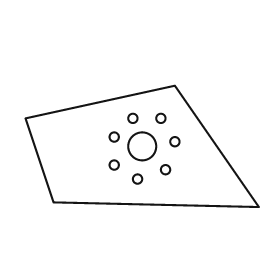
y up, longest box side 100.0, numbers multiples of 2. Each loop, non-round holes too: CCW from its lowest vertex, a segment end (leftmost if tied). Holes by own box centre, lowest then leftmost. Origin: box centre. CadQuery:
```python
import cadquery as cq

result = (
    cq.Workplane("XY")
    .moveTo(50.0, -26.0)
    .lineTo(14.0, 26.0)
    .lineTo(-50.0, 12.0)
    .lineTo(-38.0, -24.0)
    .close()
    .moveTo(-2.0, -14.0)
    .circle(2.0)
    .moveTo(10.0, -10.0)
    .circle(2.0)
    .moveTo(-12.0, -8.0)
    .circle(2.0)
    .moveTo(0.0, 0.0)
    .circle(6.0)
    .moveTo(14.0, 2.0)
    .circle(2.0)
    .moveTo(-12.0, 4.0)
    .circle(2.0)
    .moveTo(-4.0, 12.0)
    .circle(2.0)
    .moveTo(8.0, 12.0)
    .circle(2.0)
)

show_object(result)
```